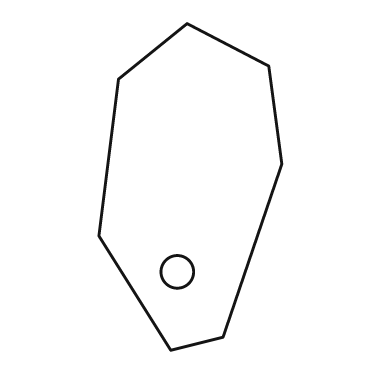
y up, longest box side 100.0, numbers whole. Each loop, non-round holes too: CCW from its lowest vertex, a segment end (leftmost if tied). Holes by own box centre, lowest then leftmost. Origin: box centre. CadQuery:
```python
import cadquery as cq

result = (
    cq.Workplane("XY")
    .moveTo(-6.0, -50.0)
    .lineTo(10.0, -46.0)
    .lineTo(28.0, 7.0)
    .lineTo(24.0, 37.0)
    .lineTo(-1.0, 50.0)
    .lineTo(-22.0, 33.0)
    .lineTo(-28.0, -15.0)
    .close()
    .moveTo(-4.0, -26.0)
    .circle(5.0)
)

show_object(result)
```